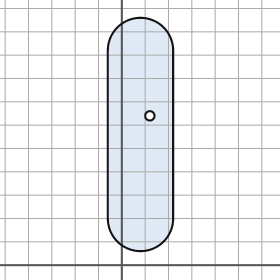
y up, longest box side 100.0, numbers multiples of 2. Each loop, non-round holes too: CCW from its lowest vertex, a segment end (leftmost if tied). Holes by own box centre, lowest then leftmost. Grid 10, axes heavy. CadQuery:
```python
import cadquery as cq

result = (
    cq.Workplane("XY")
    .moveTo(-6.0, 20.0)
    .threePointArc((8.0, 6.0), (22.0, 20.0))
    .lineTo(22.0, 92.0)
    .threePointArc((8.0, 106.0), (-6.0, 92.0))
    .close()
    .moveTo(12.0, 64.0)
    .circle(2.0)
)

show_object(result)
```